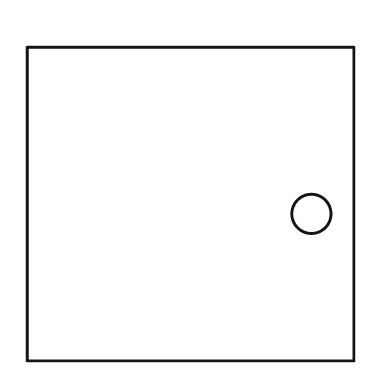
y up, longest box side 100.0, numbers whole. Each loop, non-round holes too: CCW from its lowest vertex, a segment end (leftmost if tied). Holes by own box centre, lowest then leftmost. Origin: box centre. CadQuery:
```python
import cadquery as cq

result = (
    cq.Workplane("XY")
    .moveTo(-50.0, -48.0)
    .lineTo(50.0, -48.0)
    .lineTo(50.0, 48.0)
    .lineTo(-50.0, 48.0)
    .close()
    .moveTo(37.0, -3.0)
    .circle(6.0)
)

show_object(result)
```